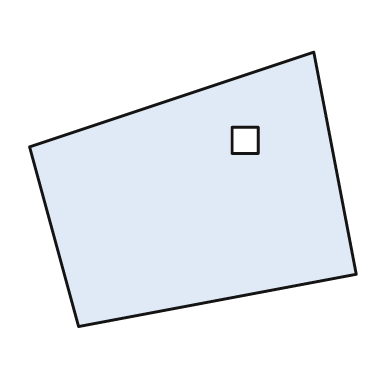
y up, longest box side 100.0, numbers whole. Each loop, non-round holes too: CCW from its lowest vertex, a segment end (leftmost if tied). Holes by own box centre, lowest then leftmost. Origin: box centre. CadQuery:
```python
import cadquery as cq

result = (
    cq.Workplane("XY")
    .moveTo(-35.0, -42.0)
    .lineTo(50.0, -26.0)
    .lineTo(37.0, 42.0)
    .lineTo(-50.0, 13.0)
    .close()
    .moveTo(12.0, 11.0)
    .lineTo(20.0, 11.0)
    .lineTo(20.0, 19.0)
    .lineTo(12.0, 19.0)
    .close()
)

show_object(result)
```